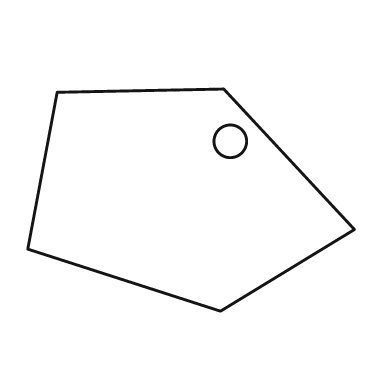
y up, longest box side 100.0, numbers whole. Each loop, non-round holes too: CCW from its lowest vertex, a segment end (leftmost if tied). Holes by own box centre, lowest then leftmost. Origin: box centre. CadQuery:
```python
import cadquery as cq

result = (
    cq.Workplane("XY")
    .moveTo(9.0, -34.0)
    .lineTo(50.0, -9.0)
    .lineTo(10.0, 34.0)
    .lineTo(-41.0, 33.0)
    .lineTo(-50.0, -15.0)
    .close()
    .moveTo(12.0, 18.0)
    .circle(5.0)
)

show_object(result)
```